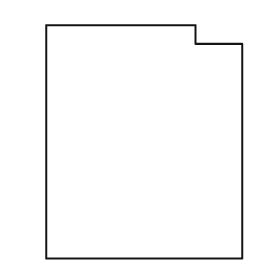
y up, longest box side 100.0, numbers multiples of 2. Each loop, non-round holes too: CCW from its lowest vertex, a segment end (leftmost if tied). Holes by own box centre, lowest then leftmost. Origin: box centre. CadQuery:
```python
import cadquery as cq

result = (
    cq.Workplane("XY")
    .moveTo(-42.0, -50.0)
    .lineTo(42.0, -50.0)
    .lineTo(42.0, 42.0)
    .lineTo(22.0, 42.0)
    .lineTo(22.0, 50.0)
    .lineTo(-42.0, 50.0)
    .close()
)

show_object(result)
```